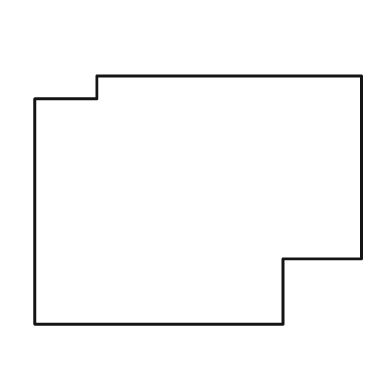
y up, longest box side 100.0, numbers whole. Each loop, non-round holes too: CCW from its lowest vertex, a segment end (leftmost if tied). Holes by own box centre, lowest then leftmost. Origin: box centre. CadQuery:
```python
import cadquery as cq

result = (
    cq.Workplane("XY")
    .moveTo(-50.0, -38.0)
    .lineTo(26.0, -38.0)
    .lineTo(26.0, -18.0)
    .lineTo(50.0, -18.0)
    .lineTo(50.0, 38.0)
    .lineTo(-31.0, 38.0)
    .lineTo(-31.0, 31.0)
    .lineTo(-50.0, 31.0)
    .close()
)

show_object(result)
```